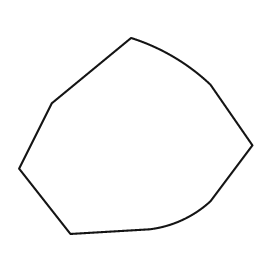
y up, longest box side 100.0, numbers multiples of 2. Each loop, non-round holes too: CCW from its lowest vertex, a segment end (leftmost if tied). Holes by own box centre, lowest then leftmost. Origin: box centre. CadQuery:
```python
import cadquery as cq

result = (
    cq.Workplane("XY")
    .moveTo(-28.0, -42.0)
    .lineTo(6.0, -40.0)
    .threePointArc((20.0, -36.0), (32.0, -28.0))
    .lineTo(50.0, -4.0)
    .lineTo(32.0, 22.0)
    .threePointArc((16.0, 34.0), (-2.0, 42.0))
    .lineTo(-36.0, 14.0)
    .lineTo(-50.0, -14.0)
    .close()
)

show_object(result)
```